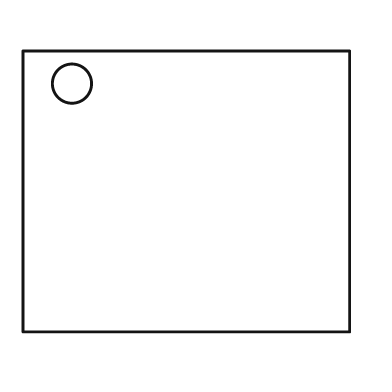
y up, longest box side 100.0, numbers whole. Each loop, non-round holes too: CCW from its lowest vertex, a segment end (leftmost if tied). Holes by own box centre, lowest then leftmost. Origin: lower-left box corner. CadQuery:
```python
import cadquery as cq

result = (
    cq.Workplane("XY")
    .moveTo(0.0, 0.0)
    .lineTo(100.0, 0.0)
    .lineTo(100.0, 86.0)
    .lineTo(0.0, 86.0)
    .close()
    .moveTo(15.0, 76.0)
    .circle(6.0)
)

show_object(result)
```